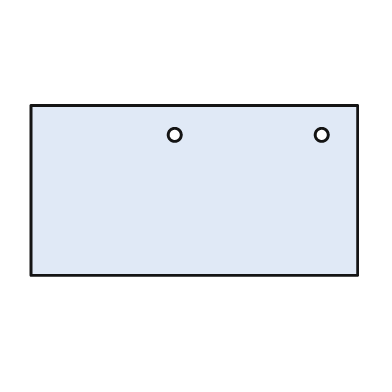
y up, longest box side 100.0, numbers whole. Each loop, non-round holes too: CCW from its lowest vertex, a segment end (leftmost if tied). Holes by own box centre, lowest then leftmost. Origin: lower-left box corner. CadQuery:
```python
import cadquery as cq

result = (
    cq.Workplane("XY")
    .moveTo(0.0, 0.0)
    .lineTo(100.0, 0.0)
    .lineTo(100.0, 52.0)
    .lineTo(0.0, 52.0)
    .close()
    .moveTo(44.0, 43.0)
    .circle(2.0)
    .moveTo(89.0, 43.0)
    .circle(2.0)
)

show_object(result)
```